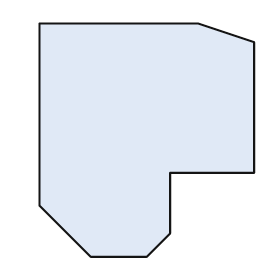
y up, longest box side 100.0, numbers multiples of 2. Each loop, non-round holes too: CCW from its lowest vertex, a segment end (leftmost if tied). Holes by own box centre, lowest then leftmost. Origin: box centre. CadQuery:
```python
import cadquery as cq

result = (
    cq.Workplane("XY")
    .moveTo(-24.0, -50.0)
    .lineTo(0.0, -50.0)
    .lineTo(10.0, -40.0)
    .lineTo(10.0, -14.0)
    .lineTo(46.0, -14.0)
    .lineTo(46.0, 42.0)
    .lineTo(22.0, 50.0)
    .lineTo(-46.0, 50.0)
    .lineTo(-46.0, -28.0)
    .close()
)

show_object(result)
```